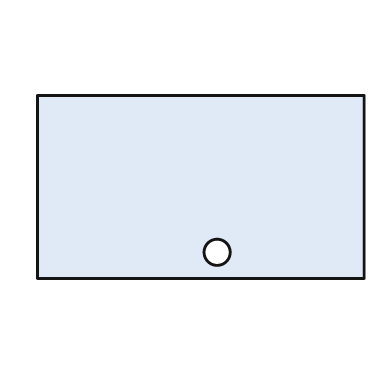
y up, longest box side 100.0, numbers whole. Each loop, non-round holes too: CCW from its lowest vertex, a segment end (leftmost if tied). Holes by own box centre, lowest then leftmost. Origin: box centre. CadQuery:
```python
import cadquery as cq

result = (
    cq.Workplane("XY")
    .moveTo(-50.0, -28.0)
    .lineTo(50.0, -28.0)
    .lineTo(50.0, 28.0)
    .lineTo(-50.0, 28.0)
    .close()
    .moveTo(5.0, -20.0)
    .circle(4.0)
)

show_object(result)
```